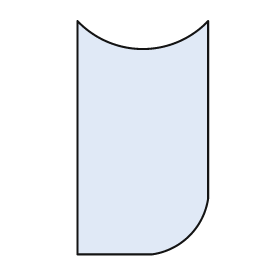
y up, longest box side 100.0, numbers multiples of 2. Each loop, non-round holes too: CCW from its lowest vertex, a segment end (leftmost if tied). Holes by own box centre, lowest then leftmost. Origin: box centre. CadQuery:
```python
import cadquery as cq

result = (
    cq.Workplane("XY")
    .moveTo(-28.0, -50.0)
    .lineTo(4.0, -50.0)
    .threePointArc((20.0, -42.0), (28.0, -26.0))
    .lineTo(28.0, 50.0)
    .threePointArc((0.0, 38.0), (-28.0, 50.0))
    .close()
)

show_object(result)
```